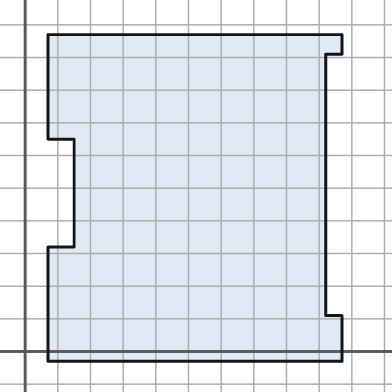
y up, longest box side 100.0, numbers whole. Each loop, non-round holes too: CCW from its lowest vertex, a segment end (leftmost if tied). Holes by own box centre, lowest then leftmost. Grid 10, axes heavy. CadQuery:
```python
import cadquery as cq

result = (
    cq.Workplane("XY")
    .moveTo(7.0, -3.0)
    .lineTo(97.0, -3.0)
    .lineTo(97.0, 11.0)
    .lineTo(92.0, 11.0)
    .lineTo(92.0, 91.0)
    .lineTo(97.0, 91.0)
    .lineTo(97.0, 97.0)
    .lineTo(7.0, 97.0)
    .lineTo(7.0, 65.0)
    .lineTo(15.0, 65.0)
    .lineTo(15.0, 32.0)
    .lineTo(7.0, 32.0)
    .close()
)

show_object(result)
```